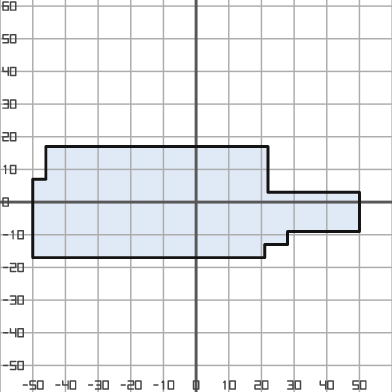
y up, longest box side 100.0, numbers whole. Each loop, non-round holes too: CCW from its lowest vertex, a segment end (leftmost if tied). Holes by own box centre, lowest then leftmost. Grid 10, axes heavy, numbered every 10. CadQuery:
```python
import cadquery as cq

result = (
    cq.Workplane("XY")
    .moveTo(-50.0, -17.0)
    .lineTo(21.0, -17.0)
    .lineTo(21.0, -13.0)
    .lineTo(28.0, -13.0)
    .lineTo(28.0, -9.0)
    .lineTo(50.0, -9.0)
    .lineTo(50.0, 3.0)
    .lineTo(22.0, 3.0)
    .lineTo(22.0, 17.0)
    .lineTo(-46.0, 17.0)
    .lineTo(-46.0, 7.0)
    .lineTo(-50.0, 7.0)
    .close()
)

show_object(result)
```